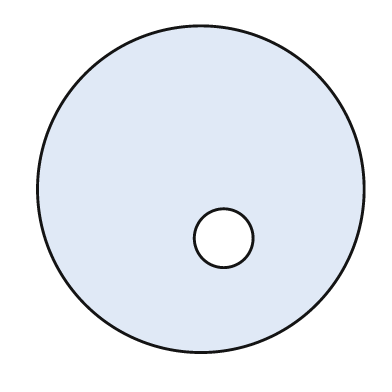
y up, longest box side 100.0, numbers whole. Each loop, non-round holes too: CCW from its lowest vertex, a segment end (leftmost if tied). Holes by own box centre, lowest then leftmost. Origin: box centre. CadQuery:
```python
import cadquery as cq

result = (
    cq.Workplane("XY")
    .moveTo(0.0, 0.0)
    .circle(50.0)
    .moveTo(7.0, -15.0)
    .circle(9.0)
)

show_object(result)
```